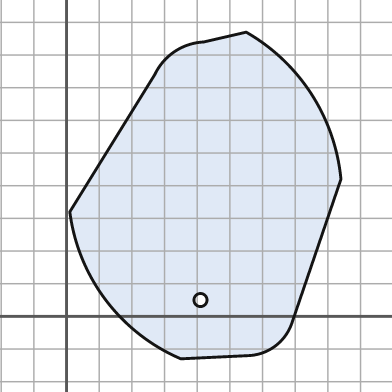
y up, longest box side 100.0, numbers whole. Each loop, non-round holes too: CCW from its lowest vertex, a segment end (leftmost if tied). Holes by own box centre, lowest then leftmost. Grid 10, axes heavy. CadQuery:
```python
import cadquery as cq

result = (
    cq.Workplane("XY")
    .moveTo(35.0, -13.0)
    .lineTo(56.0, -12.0)
    .threePointArc((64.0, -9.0), (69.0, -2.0))
    .lineTo(84.0, 42.0)
    .threePointArc((75.0, 68.0), (55.0, 87.0))
    .lineTo(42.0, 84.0)
    .threePointArc((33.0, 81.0), (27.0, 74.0))
    .lineTo(1.0, 32.0)
    .threePointArc((12.0, 5.0), (35.0, -13.0))
    .close()
    .moveTo(41.0, 5.0)
    .circle(2.0)
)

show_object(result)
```